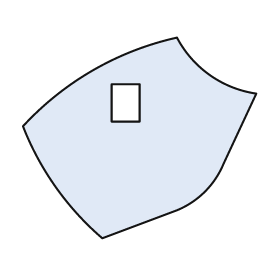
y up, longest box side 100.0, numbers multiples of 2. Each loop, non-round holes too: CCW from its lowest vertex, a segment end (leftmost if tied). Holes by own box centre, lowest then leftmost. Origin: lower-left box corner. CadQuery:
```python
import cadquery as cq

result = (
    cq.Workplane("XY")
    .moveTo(34.0, 0.0)
    .lineTo(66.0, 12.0)
    .threePointArc((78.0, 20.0), (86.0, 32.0))
    .lineTo(100.0, 62.0)
    .threePointArc((80.0, 70.0), (66.0, 86.0))
    .threePointArc((30.0, 72.0), (0.0, 48.0))
    .threePointArc((14.0, 22.0), (34.0, 0.0))
    .close()
    .moveTo(38.0, 50.0)
    .lineTo(50.0, 50.0)
    .lineTo(50.0, 66.0)
    .lineTo(38.0, 66.0)
    .close()
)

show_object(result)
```